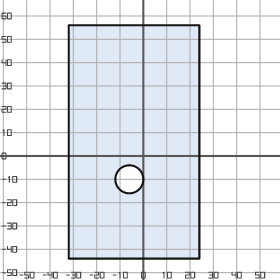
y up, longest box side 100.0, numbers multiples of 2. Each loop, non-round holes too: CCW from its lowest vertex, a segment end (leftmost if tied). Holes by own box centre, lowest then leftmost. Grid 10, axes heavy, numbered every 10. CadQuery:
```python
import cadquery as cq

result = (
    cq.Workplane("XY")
    .moveTo(-32.0, -44.0)
    .lineTo(24.0, -44.0)
    .lineTo(24.0, 56.0)
    .lineTo(-32.0, 56.0)
    .close()
    .moveTo(-6.0, -10.0)
    .circle(6.0)
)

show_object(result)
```